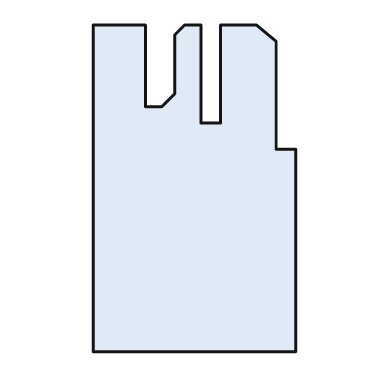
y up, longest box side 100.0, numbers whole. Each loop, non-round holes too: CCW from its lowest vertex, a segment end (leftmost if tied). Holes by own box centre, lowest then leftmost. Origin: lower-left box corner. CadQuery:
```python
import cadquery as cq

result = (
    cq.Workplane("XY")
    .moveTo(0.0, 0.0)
    .lineTo(62.0, 0.0)
    .lineTo(62.0, 62.0)
    .lineTo(56.0, 62.0)
    .lineTo(56.0, 95.0)
    .lineTo(50.0, 100.0)
    .lineTo(39.0, 100.0)
    .lineTo(39.0, 70.0)
    .lineTo(33.0, 70.0)
    .lineTo(33.0, 100.0)
    .lineTo(28.0, 100.0)
    .lineTo(25.0, 97.0)
    .lineTo(25.0, 79.0)
    .lineTo(21.0, 75.0)
    .lineTo(16.0, 75.0)
    .lineTo(16.0, 100.0)
    .lineTo(0.0, 100.0)
    .close()
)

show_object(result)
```